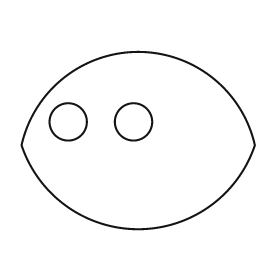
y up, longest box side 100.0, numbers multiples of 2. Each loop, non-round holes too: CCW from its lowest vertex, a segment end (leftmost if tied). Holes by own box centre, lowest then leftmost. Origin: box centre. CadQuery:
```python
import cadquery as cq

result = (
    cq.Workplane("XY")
    .moveTo(-50.0, -2.0)
    .threePointArc((0.0, -38.0), (50.0, -2.0))
    .threePointArc((0.0, 38.0), (-50.0, -2.0))
    .close()
    .moveTo(-30.0, 8.0)
    .circle(8.0)
    .moveTo(-2.0, 8.0)
    .circle(8.0)
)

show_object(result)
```